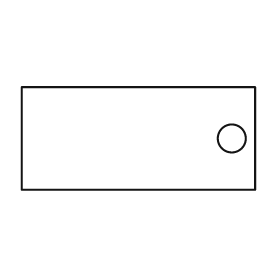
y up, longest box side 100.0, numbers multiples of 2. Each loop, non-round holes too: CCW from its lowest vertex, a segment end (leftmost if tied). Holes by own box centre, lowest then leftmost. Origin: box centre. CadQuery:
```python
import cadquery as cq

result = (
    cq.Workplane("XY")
    .moveTo(-50.0, -22.0)
    .lineTo(50.0, -22.0)
    .lineTo(50.0, 22.0)
    .lineTo(-50.0, 22.0)
    .close()
    .moveTo(40.0, 0.0)
    .circle(6.0)
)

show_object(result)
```